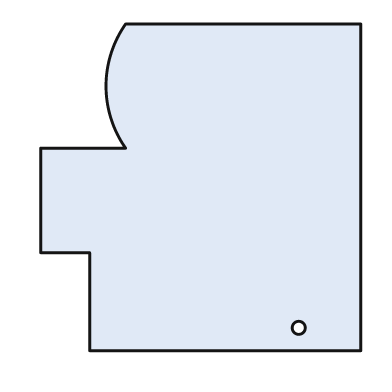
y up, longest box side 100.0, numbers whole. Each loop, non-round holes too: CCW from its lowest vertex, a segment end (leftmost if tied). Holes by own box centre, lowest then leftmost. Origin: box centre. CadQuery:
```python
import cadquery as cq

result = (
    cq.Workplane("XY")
    .moveTo(-34.0, -50.0)
    .lineTo(49.0, -50.0)
    .lineTo(49.0, 50.0)
    .lineTo(-23.0, 50.0)
    .threePointArc((-29.0, 31.0), (-23.0, 12.0))
    .lineTo(-49.0, 12.0)
    .lineTo(-49.0, -20.0)
    .lineTo(-34.0, -20.0)
    .close()
    .moveTo(30.0, -43.0)
    .circle(2.0)
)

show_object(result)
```